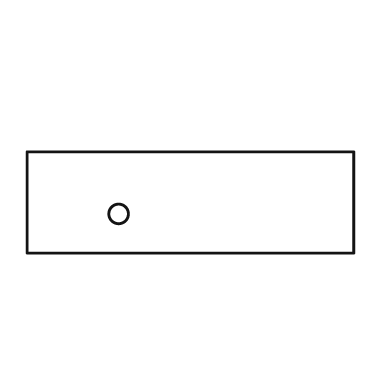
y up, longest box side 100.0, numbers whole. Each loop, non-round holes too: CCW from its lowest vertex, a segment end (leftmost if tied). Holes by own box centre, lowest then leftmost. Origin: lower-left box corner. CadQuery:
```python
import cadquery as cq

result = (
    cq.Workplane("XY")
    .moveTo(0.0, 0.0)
    .lineTo(100.0, 0.0)
    .lineTo(100.0, 31.0)
    .lineTo(0.0, 31.0)
    .close()
    .moveTo(28.0, 12.0)
    .circle(3.0)
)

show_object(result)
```